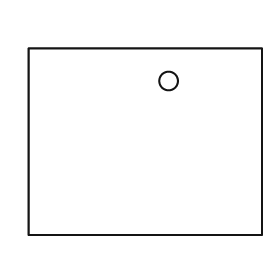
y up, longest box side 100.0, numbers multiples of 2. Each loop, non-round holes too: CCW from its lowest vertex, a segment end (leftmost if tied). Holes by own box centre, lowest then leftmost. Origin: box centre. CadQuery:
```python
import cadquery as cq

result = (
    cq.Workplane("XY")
    .moveTo(-50.0, -40.0)
    .lineTo(50.0, -40.0)
    .lineTo(50.0, 40.0)
    .lineTo(-50.0, 40.0)
    .close()
    .moveTo(10.0, 26.0)
    .circle(4.0)
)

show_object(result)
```